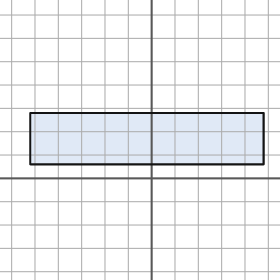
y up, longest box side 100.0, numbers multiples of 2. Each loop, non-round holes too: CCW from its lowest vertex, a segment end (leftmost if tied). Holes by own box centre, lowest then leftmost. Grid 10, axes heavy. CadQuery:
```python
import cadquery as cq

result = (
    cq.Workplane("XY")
    .moveTo(-52.0, 6.0)
    .lineTo(48.0, 6.0)
    .lineTo(48.0, 28.0)
    .lineTo(-52.0, 28.0)
    .close()
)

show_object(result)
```